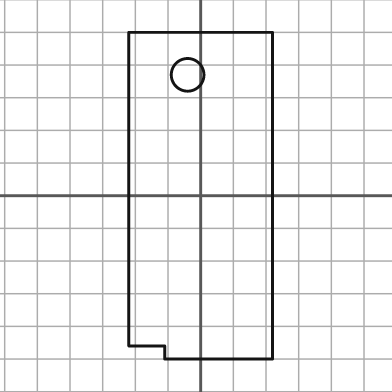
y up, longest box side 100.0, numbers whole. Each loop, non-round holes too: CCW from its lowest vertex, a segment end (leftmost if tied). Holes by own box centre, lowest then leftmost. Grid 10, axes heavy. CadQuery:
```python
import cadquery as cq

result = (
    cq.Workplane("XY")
    .moveTo(-11.0, -50.0)
    .lineTo(22.0, -50.0)
    .lineTo(22.0, 50.0)
    .lineTo(-22.0, 50.0)
    .lineTo(-22.0, -46.0)
    .lineTo(-11.0, -46.0)
    .close()
    .moveTo(-4.0, 37.0)
    .circle(5.0)
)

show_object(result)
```